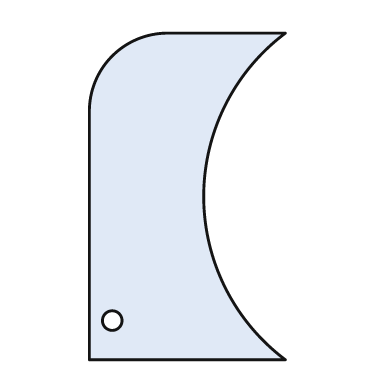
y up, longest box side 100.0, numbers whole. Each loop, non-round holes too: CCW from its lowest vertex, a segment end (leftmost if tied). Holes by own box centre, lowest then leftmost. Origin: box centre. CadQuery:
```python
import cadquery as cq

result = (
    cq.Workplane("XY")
    .moveTo(-30.0, -50.0)
    .lineTo(30.0, -50.0)
    .threePointArc((5.0, 0.0), (30.0, 50.0))
    .lineTo(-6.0, 50.0)
    .threePointArc((-23.0, 43.0), (-30.0, 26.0))
    .close()
    .moveTo(-23.0, -38.0)
    .circle(3.0)
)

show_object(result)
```